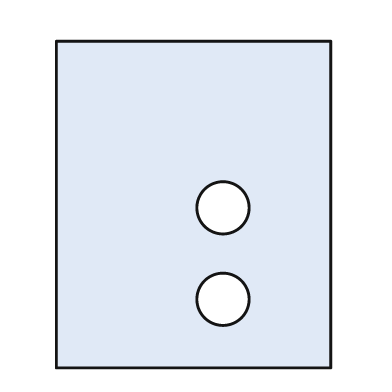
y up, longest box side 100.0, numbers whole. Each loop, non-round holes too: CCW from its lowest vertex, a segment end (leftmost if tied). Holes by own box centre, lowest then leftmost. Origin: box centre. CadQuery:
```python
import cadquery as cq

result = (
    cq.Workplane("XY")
    .moveTo(-42.0, -50.0)
    .lineTo(42.0, -50.0)
    .lineTo(42.0, 50.0)
    .lineTo(-42.0, 50.0)
    .close()
    .moveTo(9.0, -29.0)
    .circle(8.0)
    .moveTo(9.0, -1.0)
    .circle(8.0)
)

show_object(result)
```